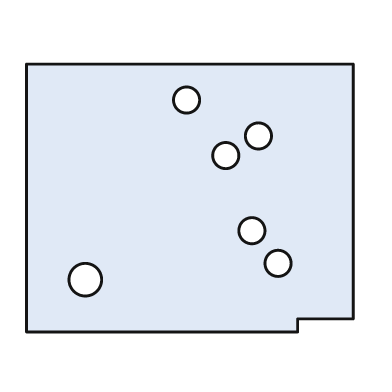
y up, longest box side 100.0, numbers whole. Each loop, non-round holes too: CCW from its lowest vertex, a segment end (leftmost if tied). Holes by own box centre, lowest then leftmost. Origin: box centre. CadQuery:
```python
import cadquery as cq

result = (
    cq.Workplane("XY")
    .moveTo(-50.0, -41.0)
    .lineTo(33.0, -41.0)
    .lineTo(33.0, -37.0)
    .lineTo(50.0, -37.0)
    .lineTo(50.0, 41.0)
    .lineTo(-50.0, 41.0)
    .close()
    .moveTo(-32.0, -25.0)
    .circle(5.0)
    .moveTo(27.0, -20.0)
    .circle(4.0)
    .moveTo(19.0, -10.0)
    .circle(4.0)
    .moveTo(11.0, 13.0)
    .circle(4.0)
    .moveTo(21.0, 19.0)
    .circle(4.0)
    .moveTo(-1.0, 30.0)
    .circle(4.0)
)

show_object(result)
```